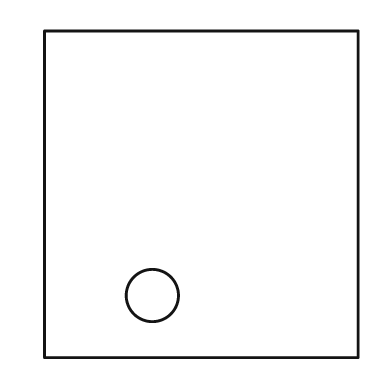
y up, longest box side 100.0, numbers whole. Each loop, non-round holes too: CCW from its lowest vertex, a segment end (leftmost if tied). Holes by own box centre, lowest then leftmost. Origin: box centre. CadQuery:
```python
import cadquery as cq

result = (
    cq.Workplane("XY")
    .moveTo(-48.0, -50.0)
    .lineTo(48.0, -50.0)
    .lineTo(48.0, 50.0)
    .lineTo(-48.0, 50.0)
    .close()
    .moveTo(-15.0, -31.0)
    .circle(8.0)
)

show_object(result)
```